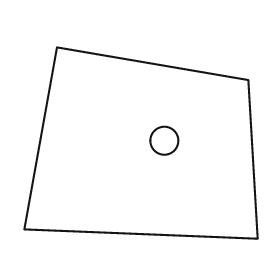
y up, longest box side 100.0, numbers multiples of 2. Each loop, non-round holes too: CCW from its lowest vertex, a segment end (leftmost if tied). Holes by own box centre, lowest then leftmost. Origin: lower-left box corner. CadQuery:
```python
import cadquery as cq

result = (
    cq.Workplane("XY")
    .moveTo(100.0, 0.0)
    .lineTo(96.0, 68.0)
    .lineTo(14.0, 82.0)
    .lineTo(0.0, 4.0)
    .close()
    .moveTo(60.0, 42.0)
    .circle(6.0)
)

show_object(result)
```